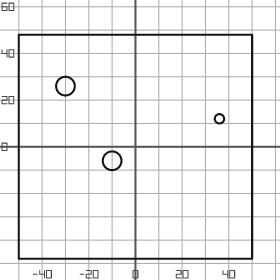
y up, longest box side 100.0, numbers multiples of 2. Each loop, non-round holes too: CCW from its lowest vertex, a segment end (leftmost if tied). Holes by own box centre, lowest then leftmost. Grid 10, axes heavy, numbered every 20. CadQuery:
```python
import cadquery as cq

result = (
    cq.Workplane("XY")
    .moveTo(-50.0, -48.0)
    .lineTo(50.0, -48.0)
    .lineTo(50.0, 48.0)
    .lineTo(-50.0, 48.0)
    .close()
    .moveTo(-10.0, -6.0)
    .circle(4.0)
    .moveTo(36.0, 12.0)
    .circle(2.0)
    .moveTo(-30.0, 26.0)
    .circle(4.0)
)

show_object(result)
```